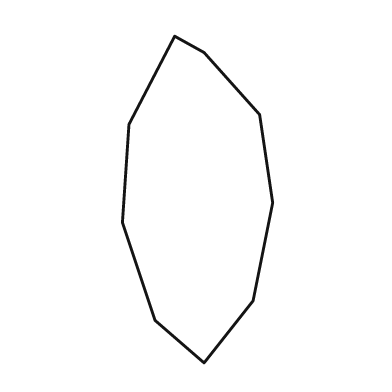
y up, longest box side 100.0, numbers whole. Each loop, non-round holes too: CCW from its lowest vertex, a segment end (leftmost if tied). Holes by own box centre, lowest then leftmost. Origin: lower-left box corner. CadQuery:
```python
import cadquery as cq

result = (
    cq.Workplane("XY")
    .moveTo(25.0, 0.0)
    .lineTo(40.0, 19.0)
    .lineTo(46.0, 49.0)
    .lineTo(42.0, 76.0)
    .lineTo(25.0, 95.0)
    .lineTo(16.0, 100.0)
    .lineTo(2.0, 73.0)
    .lineTo(0.0, 43.0)
    .lineTo(10.0, 13.0)
    .close()
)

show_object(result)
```